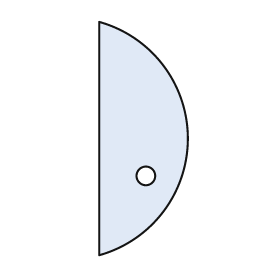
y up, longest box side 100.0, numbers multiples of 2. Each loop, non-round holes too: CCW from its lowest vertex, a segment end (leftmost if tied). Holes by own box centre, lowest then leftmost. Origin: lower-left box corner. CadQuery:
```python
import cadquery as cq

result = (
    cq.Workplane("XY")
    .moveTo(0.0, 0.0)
    .threePointArc((38.0, 50.0), (0.0, 100.0))
    .close()
    .moveTo(20.0, 34.0)
    .circle(4.0)
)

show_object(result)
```